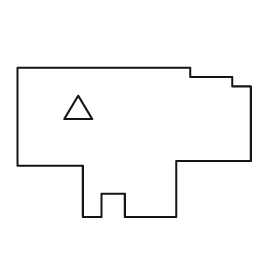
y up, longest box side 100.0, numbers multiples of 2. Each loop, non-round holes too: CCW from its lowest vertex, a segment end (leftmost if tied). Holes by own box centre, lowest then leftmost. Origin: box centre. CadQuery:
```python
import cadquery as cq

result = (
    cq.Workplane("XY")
    .moveTo(-22.0, -32.0)
    .lineTo(-14.0, -32.0)
    .lineTo(-14.0, -22.0)
    .lineTo(-4.0, -22.0)
    .lineTo(-4.0, -32.0)
    .lineTo(18.0, -32.0)
    .lineTo(18.0, -8.0)
    .lineTo(50.0, -8.0)
    .lineTo(50.0, 24.0)
    .lineTo(42.0, 24.0)
    .lineTo(42.0, 28.0)
    .lineTo(24.0, 28.0)
    .lineTo(24.0, 32.0)
    .lineTo(-50.0, 32.0)
    .lineTo(-50.0, -10.0)
    .lineTo(-22.0, -10.0)
    .close()
    .moveTo(-30.0, 10.0)
    .lineTo(-18.0, 10.0)
    .lineTo(-24.0, 20.0)
    .close()
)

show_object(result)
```